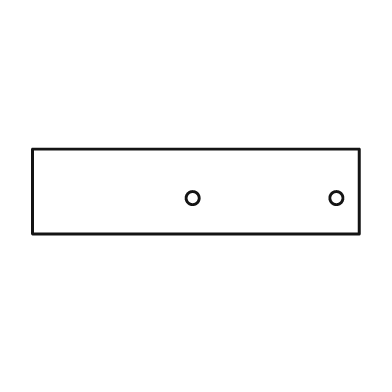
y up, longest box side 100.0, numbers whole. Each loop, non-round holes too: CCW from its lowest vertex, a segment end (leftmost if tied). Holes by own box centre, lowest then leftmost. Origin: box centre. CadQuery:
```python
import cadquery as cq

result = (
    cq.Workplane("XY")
    .moveTo(-50.0, -13.0)
    .lineTo(50.0, -13.0)
    .lineTo(50.0, 13.0)
    .lineTo(-50.0, 13.0)
    .close()
    .moveTo(-1.0, -2.0)
    .circle(2.0)
    .moveTo(43.0, -2.0)
    .circle(2.0)
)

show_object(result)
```